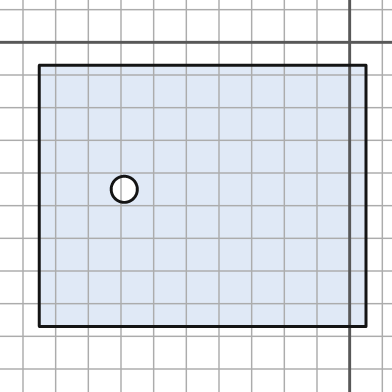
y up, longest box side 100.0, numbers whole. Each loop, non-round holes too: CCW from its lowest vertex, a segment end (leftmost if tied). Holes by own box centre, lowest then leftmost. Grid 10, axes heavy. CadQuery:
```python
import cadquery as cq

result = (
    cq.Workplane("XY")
    .moveTo(-95.0, -87.0)
    .lineTo(5.0, -87.0)
    .lineTo(5.0, -7.0)
    .lineTo(-95.0, -7.0)
    .close()
    .moveTo(-69.0, -45.0)
    .circle(4.0)
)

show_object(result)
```